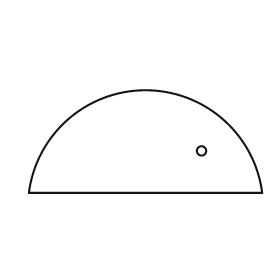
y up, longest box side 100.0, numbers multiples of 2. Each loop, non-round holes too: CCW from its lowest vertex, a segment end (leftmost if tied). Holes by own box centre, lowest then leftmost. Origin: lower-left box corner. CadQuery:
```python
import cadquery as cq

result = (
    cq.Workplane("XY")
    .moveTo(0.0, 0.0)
    .lineTo(100.0, 0.0)
    .threePointArc((50.0, 44.0), (0.0, 0.0))
    .close()
    .moveTo(74.0, 18.0)
    .circle(2.0)
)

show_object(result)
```